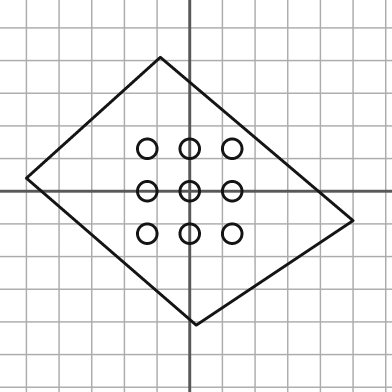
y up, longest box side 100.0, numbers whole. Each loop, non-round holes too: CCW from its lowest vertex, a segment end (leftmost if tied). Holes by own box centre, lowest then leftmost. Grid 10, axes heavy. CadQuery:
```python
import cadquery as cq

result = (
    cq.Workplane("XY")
    .moveTo(2.0, -41.0)
    .lineTo(50.0, -9.0)
    .lineTo(-9.0, 41.0)
    .lineTo(-50.0, 4.0)
    .close()
    .moveTo(-13.0, -13.0)
    .circle(3.0)
    .moveTo(0.0, -13.0)
    .circle(3.0)
    .moveTo(13.0, -13.0)
    .circle(3.0)
    .moveTo(-13.0, 0.0)
    .circle(3.0)
    .moveTo(0.0, 0.0)
    .circle(3.0)
    .moveTo(13.0, 0.0)
    .circle(3.0)
    .moveTo(-13.0, 13.0)
    .circle(3.0)
    .moveTo(0.0, 13.0)
    .circle(3.0)
    .moveTo(13.0, 13.0)
    .circle(3.0)
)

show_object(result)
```